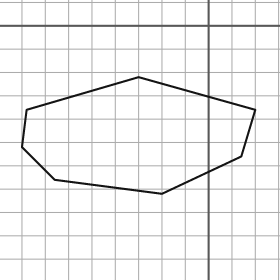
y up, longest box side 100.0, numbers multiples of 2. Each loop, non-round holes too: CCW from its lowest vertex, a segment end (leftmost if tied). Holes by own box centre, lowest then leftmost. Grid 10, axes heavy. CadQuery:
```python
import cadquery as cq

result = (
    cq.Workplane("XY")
    .moveTo(-20.0, -72.0)
    .lineTo(14.0, -56.0)
    .lineTo(20.0, -36.0)
    .lineTo(-30.0, -22.0)
    .lineTo(-78.0, -36.0)
    .lineTo(-80.0, -52.0)
    .lineTo(-66.0, -66.0)
    .close()
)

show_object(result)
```